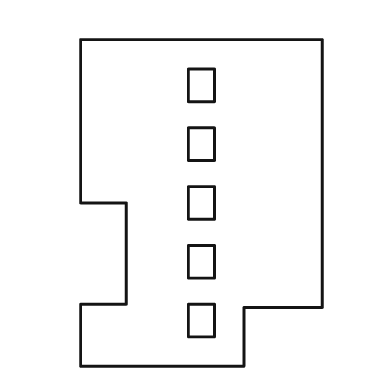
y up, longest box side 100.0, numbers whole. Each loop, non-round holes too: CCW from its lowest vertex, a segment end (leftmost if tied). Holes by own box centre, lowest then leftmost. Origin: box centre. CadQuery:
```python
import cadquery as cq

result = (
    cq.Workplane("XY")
    .moveTo(-37.0, -50.0)
    .lineTo(13.0, -50.0)
    .lineTo(13.0, -32.0)
    .lineTo(37.0, -32.0)
    .lineTo(37.0, 50.0)
    .lineTo(-37.0, 50.0)
    .lineTo(-37.0, 0.0)
    .lineTo(-23.0, 0.0)
    .lineTo(-23.0, -31.0)
    .lineTo(-37.0, -31.0)
    .close()
    .moveTo(-4.0, -41.0)
    .lineTo(4.0, -41.0)
    .lineTo(4.0, -31.0)
    .lineTo(-4.0, -31.0)
    .close()
    .moveTo(-4.0, -23.0)
    .lineTo(4.0, -23.0)
    .lineTo(4.0, -13.0)
    .lineTo(-4.0, -13.0)
    .close()
    .moveTo(-4.0, -5.0)
    .lineTo(4.0, -5.0)
    .lineTo(4.0, 5.0)
    .lineTo(-4.0, 5.0)
    .close()
    .moveTo(-4.0, 13.0)
    .lineTo(4.0, 13.0)
    .lineTo(4.0, 23.0)
    .lineTo(-4.0, 23.0)
    .close()
    .moveTo(-4.0, 31.0)
    .lineTo(4.0, 31.0)
    .lineTo(4.0, 41.0)
    .lineTo(-4.0, 41.0)
    .close()
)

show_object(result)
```